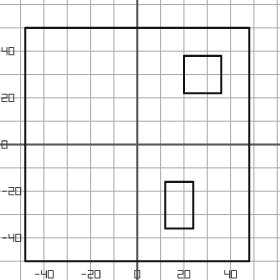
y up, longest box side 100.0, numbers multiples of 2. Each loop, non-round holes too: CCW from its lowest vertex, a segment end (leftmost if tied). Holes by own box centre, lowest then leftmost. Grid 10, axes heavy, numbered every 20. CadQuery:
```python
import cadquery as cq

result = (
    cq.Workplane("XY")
    .moveTo(-48.0, -50.0)
    .lineTo(48.0, -50.0)
    .lineTo(48.0, 50.0)
    .lineTo(-48.0, 50.0)
    .close()
    .moveTo(12.0, -36.0)
    .lineTo(24.0, -36.0)
    .lineTo(24.0, -16.0)
    .lineTo(12.0, -16.0)
    .close()
    .moveTo(20.0, 22.0)
    .lineTo(36.0, 22.0)
    .lineTo(36.0, 38.0)
    .lineTo(20.0, 38.0)
    .close()
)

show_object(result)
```